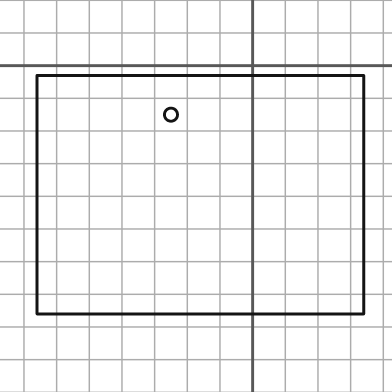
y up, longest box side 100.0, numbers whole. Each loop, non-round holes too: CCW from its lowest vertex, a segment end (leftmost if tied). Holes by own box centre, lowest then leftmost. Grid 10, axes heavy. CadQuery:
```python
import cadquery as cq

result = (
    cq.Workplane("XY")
    .moveTo(-66.0, -76.0)
    .lineTo(34.0, -76.0)
    .lineTo(34.0, -3.0)
    .lineTo(-66.0, -3.0)
    .close()
    .moveTo(-25.0, -15.0)
    .circle(2.0)
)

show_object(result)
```